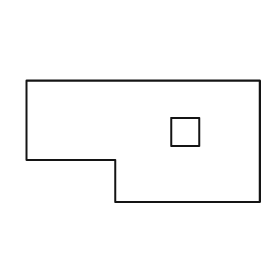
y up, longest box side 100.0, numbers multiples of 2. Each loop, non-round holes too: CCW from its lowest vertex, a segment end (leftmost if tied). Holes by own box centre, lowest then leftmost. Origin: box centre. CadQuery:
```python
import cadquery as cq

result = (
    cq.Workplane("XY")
    .moveTo(-12.0, -26.0)
    .lineTo(50.0, -26.0)
    .lineTo(50.0, 26.0)
    .lineTo(-50.0, 26.0)
    .lineTo(-50.0, -8.0)
    .lineTo(-12.0, -8.0)
    .close()
    .moveTo(12.0, -2.0)
    .lineTo(24.0, -2.0)
    .lineTo(24.0, 10.0)
    .lineTo(12.0, 10.0)
    .close()
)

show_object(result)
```